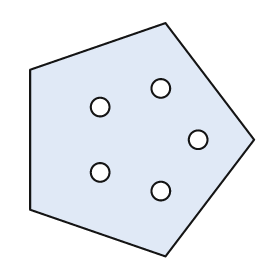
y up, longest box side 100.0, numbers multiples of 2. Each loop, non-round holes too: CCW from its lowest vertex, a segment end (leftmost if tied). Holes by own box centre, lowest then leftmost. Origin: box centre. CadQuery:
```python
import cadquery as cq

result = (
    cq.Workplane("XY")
    .moveTo(10.0, -50.0)
    .lineTo(48.0, 0.0)
    .lineTo(10.0, 50.0)
    .lineTo(-48.0, 30.0)
    .lineTo(-48.0, -30.0)
    .close()
    .moveTo(8.0, -22.0)
    .circle(4.0)
    .moveTo(-18.0, -14.0)
    .circle(4.0)
    .moveTo(24.0, 0.0)
    .circle(4.0)
    .moveTo(-18.0, 14.0)
    .circle(4.0)
    .moveTo(8.0, 22.0)
    .circle(4.0)
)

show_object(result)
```